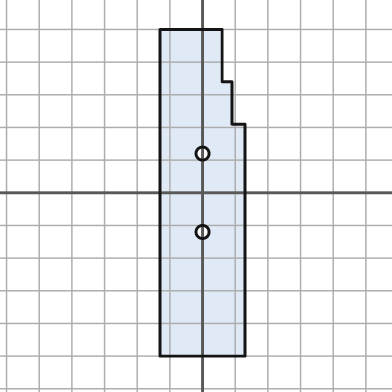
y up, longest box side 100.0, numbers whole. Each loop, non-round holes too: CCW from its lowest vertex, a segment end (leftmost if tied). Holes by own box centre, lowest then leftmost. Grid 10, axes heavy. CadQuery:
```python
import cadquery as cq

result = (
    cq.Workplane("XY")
    .moveTo(-13.0, -50.0)
    .lineTo(13.0, -50.0)
    .lineTo(13.0, 21.0)
    .lineTo(9.0, 21.0)
    .lineTo(9.0, 34.0)
    .lineTo(6.0, 34.0)
    .lineTo(6.0, 50.0)
    .lineTo(-13.0, 50.0)
    .close()
    .moveTo(0.0, -12.0)
    .circle(2.0)
    .moveTo(0.0, 12.0)
    .circle(2.0)
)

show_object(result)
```